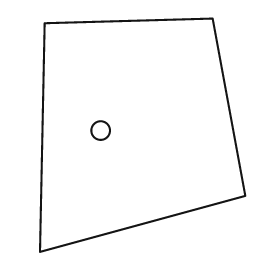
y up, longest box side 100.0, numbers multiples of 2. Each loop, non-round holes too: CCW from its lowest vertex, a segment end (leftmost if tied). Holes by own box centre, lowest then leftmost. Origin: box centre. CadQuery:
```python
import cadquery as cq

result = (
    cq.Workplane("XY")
    .moveTo(-44.0, -50.0)
    .lineTo(44.0, -26.0)
    .lineTo(30.0, 50.0)
    .lineTo(-42.0, 48.0)
    .close()
    .moveTo(-18.0, 2.0)
    .circle(4.0)
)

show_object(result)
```